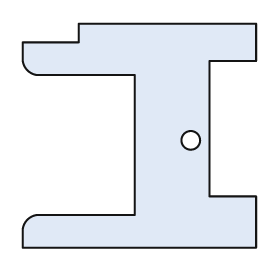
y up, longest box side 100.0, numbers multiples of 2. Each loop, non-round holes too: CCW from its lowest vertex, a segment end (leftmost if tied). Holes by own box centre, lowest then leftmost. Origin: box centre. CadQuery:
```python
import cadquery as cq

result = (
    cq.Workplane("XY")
    .moveTo(-50.0, -48.0)
    .lineTo(50.0, -48.0)
    .lineTo(50.0, -26.0)
    .lineTo(30.0, -26.0)
    .lineTo(30.0, 32.0)
    .lineTo(50.0, 32.0)
    .lineTo(50.0, 48.0)
    .lineTo(-26.0, 48.0)
    .lineTo(-26.0, 40.0)
    .lineTo(-50.0, 40.0)
    .lineTo(-50.0, 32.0)
    .threePointArc((-48.0, 28.0), (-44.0, 26.0))
    .lineTo(-2.0, 26.0)
    .lineTo(-2.0, -34.0)
    .lineTo(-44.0, -34.0)
    .threePointArc((-48.0, -36.0), (-50.0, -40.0))
    .close()
    .moveTo(22.0, -2.0)
    .circle(4.0)
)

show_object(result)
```